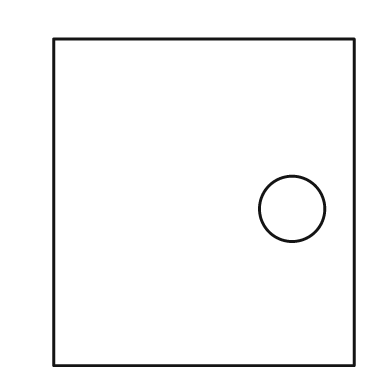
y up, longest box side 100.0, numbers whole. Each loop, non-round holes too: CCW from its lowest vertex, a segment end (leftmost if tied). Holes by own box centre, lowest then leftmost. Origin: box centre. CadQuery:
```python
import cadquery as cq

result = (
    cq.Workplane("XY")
    .moveTo(-46.0, -50.0)
    .lineTo(46.0, -50.0)
    .lineTo(46.0, 50.0)
    .lineTo(-46.0, 50.0)
    .close()
    .moveTo(27.0, -2.0)
    .circle(10.0)
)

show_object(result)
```